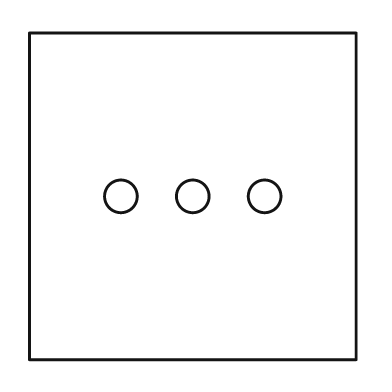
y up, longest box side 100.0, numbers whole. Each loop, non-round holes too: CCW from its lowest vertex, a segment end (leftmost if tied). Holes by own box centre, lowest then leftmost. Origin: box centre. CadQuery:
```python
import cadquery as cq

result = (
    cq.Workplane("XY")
    .moveTo(-50.0, -50.0)
    .lineTo(50.0, -50.0)
    .lineTo(50.0, 50.0)
    .lineTo(-50.0, 50.0)
    .close()
    .moveTo(-22.0, 0.0)
    .circle(5.0)
    .moveTo(0.0, 0.0)
    .circle(5.0)
    .moveTo(22.0, 0.0)
    .circle(5.0)
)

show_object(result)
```